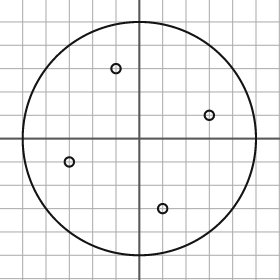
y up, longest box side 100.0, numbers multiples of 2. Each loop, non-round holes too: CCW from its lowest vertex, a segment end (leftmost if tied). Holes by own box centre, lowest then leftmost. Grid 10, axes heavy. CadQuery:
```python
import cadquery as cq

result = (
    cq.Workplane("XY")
    .moveTo(0.0, 0.0)
    .circle(50.0)
    .moveTo(10.0, -30.0)
    .circle(2.0)
    .moveTo(-30.0, -10.0)
    .circle(2.0)
    .moveTo(30.0, 10.0)
    .circle(2.0)
    .moveTo(-10.0, 30.0)
    .circle(2.0)
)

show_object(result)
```